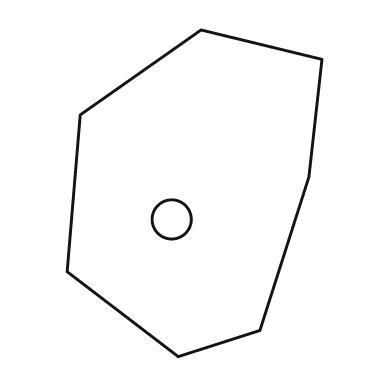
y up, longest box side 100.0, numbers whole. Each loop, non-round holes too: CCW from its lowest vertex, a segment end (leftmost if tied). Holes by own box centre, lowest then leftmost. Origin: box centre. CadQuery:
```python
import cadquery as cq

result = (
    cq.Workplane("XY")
    .moveTo(-5.0, -50.0)
    .lineTo(20.0, -42.0)
    .lineTo(35.0, 5.0)
    .lineTo(39.0, 41.0)
    .lineTo(2.0, 50.0)
    .lineTo(-35.0, 24.0)
    .lineTo(-39.0, -24.0)
    .close()
    .moveTo(-7.0, -8.0)
    .circle(6.0)
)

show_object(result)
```